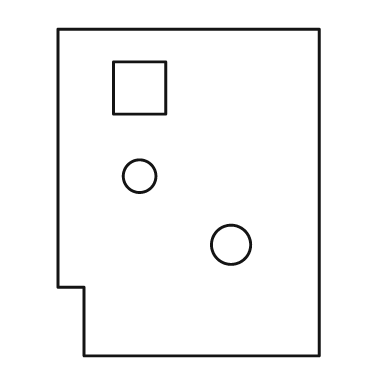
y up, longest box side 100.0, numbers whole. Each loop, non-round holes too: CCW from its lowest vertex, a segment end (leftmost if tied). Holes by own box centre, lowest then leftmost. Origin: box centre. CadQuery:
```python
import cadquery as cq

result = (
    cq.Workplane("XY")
    .moveTo(-32.0, -50.0)
    .lineTo(40.0, -50.0)
    .lineTo(40.0, 50.0)
    .lineTo(-40.0, 50.0)
    .lineTo(-40.0, -29.0)
    .lineTo(-32.0, -29.0)
    .close()
    .moveTo(13.0, -16.0)
    .circle(6.0)
    .moveTo(-15.0, 5.0)
    .circle(5.0)
    .moveTo(-23.0, 24.0)
    .lineTo(-7.0, 24.0)
    .lineTo(-7.0, 40.0)
    .lineTo(-23.0, 40.0)
    .close()
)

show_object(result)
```